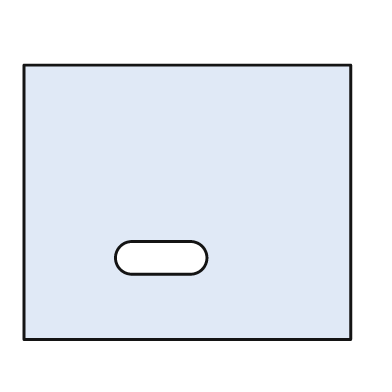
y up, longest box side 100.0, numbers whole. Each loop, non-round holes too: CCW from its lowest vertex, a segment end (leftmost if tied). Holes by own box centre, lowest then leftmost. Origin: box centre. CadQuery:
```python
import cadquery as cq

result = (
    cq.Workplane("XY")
    .moveTo(-50.0, -42.0)
    .lineTo(50.0, -42.0)
    .lineTo(50.0, 42.0)
    .lineTo(-50.0, 42.0)
    .close()
    .moveTo(-17.0, -22.0)
    .lineTo(1.0, -22.0)
    .threePointArc((6.0, -17.0), (1.0, -12.0))
    .lineTo(-17.0, -12.0)
    .threePointArc((-22.0, -17.0), (-17.0, -22.0))
    .close()
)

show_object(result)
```